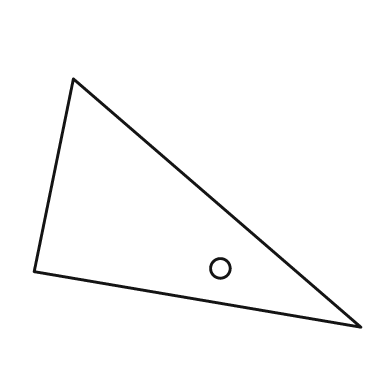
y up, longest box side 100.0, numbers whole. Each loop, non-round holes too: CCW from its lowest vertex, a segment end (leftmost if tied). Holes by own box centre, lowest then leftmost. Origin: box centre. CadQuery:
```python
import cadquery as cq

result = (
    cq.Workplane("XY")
    .moveTo(50.0, -38.0)
    .lineTo(-38.0, 38.0)
    .lineTo(-50.0, -21.0)
    .close()
    .moveTo(7.0, -20.0)
    .circle(3.0)
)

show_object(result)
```